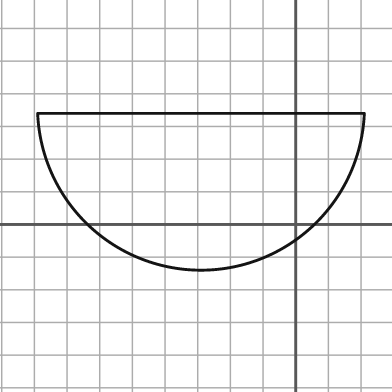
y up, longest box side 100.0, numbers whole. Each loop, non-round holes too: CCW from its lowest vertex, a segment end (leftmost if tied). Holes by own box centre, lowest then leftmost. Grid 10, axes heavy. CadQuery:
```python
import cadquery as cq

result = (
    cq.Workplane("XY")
    .moveTo(-79.0, 34.0)
    .threePointArc((-29.0, -14.0), (21.0, 34.0))
    .close()
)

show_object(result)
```